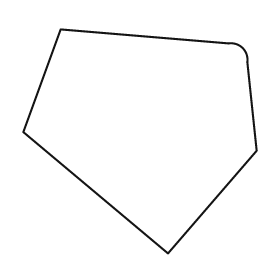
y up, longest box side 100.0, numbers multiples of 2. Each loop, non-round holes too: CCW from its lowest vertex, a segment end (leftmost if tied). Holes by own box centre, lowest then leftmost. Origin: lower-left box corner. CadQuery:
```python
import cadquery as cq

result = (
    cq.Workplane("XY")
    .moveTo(62.0, 0.0)
    .lineTo(100.0, 44.0)
    .lineTo(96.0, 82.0)
    .threePointArc((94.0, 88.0), (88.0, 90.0))
    .lineTo(16.0, 96.0)
    .lineTo(0.0, 52.0)
    .close()
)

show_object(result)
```